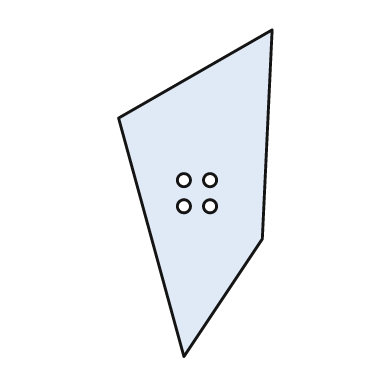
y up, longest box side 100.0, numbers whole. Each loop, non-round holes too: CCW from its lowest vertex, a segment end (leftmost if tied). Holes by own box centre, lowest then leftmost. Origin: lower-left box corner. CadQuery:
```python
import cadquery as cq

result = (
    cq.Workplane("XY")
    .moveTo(20.0, 0.0)
    .lineTo(44.0, 36.0)
    .lineTo(47.0, 100.0)
    .lineTo(0.0, 73.0)
    .close()
    .moveTo(20.0, 46.0)
    .circle(2.0)
    .moveTo(28.0, 46.0)
    .circle(2.0)
    .moveTo(20.0, 54.0)
    .circle(2.0)
    .moveTo(28.0, 54.0)
    .circle(2.0)
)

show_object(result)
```